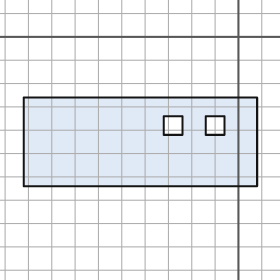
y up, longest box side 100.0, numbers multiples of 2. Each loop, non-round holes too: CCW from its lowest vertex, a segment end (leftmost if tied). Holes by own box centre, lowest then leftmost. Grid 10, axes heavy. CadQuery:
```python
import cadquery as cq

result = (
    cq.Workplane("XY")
    .moveTo(-92.0, -64.0)
    .lineTo(8.0, -64.0)
    .lineTo(8.0, -26.0)
    .lineTo(-92.0, -26.0)
    .close()
    .moveTo(-32.0, -42.0)
    .lineTo(-24.0, -42.0)
    .lineTo(-24.0, -34.0)
    .lineTo(-32.0, -34.0)
    .close()
    .moveTo(-14.0, -42.0)
    .lineTo(-6.0, -42.0)
    .lineTo(-6.0, -34.0)
    .lineTo(-14.0, -34.0)
    .close()
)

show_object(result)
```